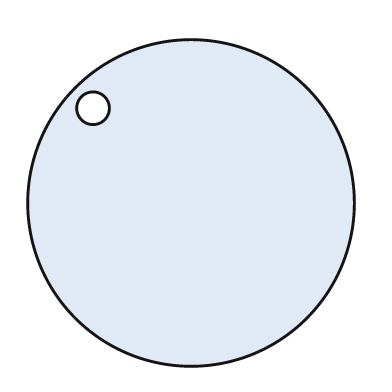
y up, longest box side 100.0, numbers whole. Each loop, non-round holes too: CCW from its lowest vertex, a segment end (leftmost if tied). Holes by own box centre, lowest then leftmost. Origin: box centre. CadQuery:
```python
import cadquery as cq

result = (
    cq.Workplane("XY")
    .moveTo(0.0, 0.0)
    .circle(50.0)
    .moveTo(-30.0, 29.0)
    .circle(5.0)
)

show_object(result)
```